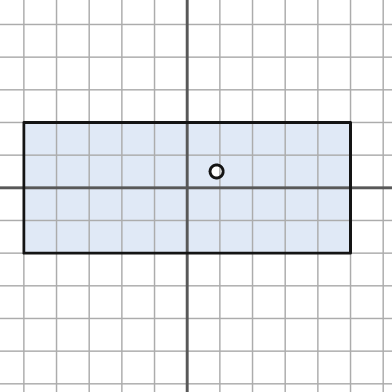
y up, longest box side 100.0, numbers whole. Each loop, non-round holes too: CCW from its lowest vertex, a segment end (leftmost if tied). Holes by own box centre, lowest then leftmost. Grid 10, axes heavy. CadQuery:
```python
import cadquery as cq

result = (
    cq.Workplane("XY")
    .moveTo(-50.0, -20.0)
    .lineTo(50.0, -20.0)
    .lineTo(50.0, 20.0)
    .lineTo(-50.0, 20.0)
    .close()
    .moveTo(9.0, 5.0)
    .circle(2.0)
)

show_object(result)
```